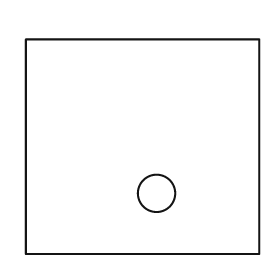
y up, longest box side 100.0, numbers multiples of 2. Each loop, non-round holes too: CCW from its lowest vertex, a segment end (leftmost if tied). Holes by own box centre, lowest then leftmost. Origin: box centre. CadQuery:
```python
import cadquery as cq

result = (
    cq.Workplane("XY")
    .moveTo(-50.0, -46.0)
    .lineTo(50.0, -46.0)
    .lineTo(50.0, 46.0)
    .lineTo(-50.0, 46.0)
    .close()
    .moveTo(6.0, -20.0)
    .circle(8.0)
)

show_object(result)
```